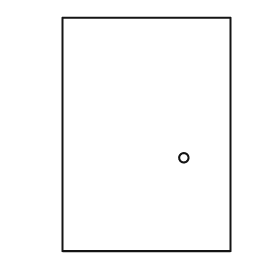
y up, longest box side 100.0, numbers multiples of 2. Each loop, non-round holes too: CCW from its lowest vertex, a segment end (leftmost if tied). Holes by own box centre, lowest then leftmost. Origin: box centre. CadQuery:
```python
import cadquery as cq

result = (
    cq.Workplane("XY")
    .moveTo(-36.0, -50.0)
    .lineTo(36.0, -50.0)
    .lineTo(36.0, 50.0)
    .lineTo(-36.0, 50.0)
    .close()
    .moveTo(16.0, -10.0)
    .circle(2.0)
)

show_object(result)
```